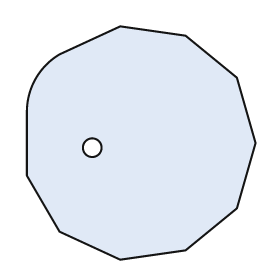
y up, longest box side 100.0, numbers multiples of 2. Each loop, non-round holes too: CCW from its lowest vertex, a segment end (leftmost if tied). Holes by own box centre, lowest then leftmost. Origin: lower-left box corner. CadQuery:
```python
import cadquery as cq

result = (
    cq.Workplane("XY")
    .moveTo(40.0, 0.0)
    .lineTo(68.0, 4.0)
    .lineTo(90.0, 22.0)
    .lineTo(98.0, 50.0)
    .lineTo(90.0, 78.0)
    .lineTo(68.0, 96.0)
    .lineTo(40.0, 100.0)
    .lineTo(14.0, 88.0)
    .threePointArc((4.0, 78.0), (0.0, 64.0))
    .lineTo(0.0, 36.0)
    .lineTo(14.0, 12.0)
    .close()
    .moveTo(28.0, 48.0)
    .circle(4.0)
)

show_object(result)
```